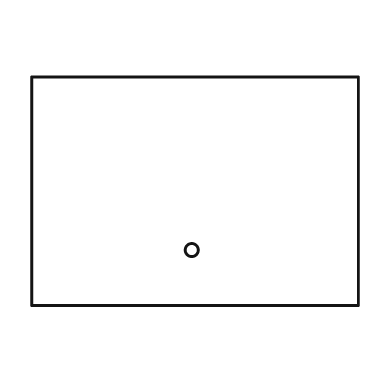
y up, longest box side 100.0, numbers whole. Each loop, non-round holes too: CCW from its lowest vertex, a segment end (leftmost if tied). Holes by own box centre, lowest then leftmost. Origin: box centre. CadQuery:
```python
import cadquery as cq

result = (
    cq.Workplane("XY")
    .moveTo(-50.0, -35.0)
    .lineTo(50.0, -35.0)
    .lineTo(50.0, 35.0)
    .lineTo(-50.0, 35.0)
    .close()
    .moveTo(-1.0, -18.0)
    .circle(2.0)
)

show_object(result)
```